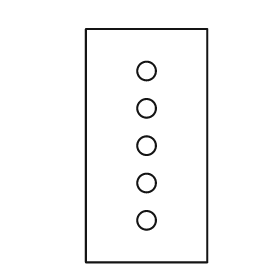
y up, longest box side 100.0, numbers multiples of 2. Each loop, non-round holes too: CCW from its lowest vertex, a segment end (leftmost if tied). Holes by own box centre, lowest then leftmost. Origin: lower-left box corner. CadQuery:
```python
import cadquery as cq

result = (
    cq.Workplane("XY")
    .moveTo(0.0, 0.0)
    .lineTo(52.0, 0.0)
    .lineTo(52.0, 100.0)
    .lineTo(0.0, 100.0)
    .close()
    .moveTo(26.0, 18.0)
    .circle(4.0)
    .moveTo(26.0, 34.0)
    .circle(4.0)
    .moveTo(26.0, 50.0)
    .circle(4.0)
    .moveTo(26.0, 66.0)
    .circle(4.0)
    .moveTo(26.0, 82.0)
    .circle(4.0)
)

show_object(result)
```